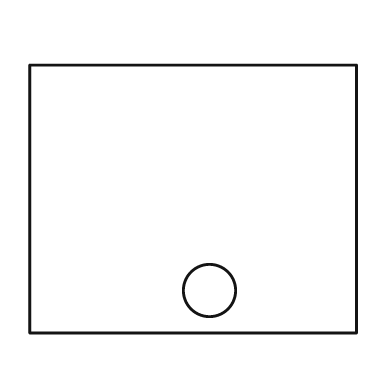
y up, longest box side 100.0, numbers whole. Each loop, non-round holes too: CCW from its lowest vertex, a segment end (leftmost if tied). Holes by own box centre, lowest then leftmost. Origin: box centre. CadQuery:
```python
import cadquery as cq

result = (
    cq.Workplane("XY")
    .moveTo(-50.0, -41.0)
    .lineTo(50.0, -41.0)
    .lineTo(50.0, 41.0)
    .lineTo(-50.0, 41.0)
    .close()
    .moveTo(5.0, -28.0)
    .circle(8.0)
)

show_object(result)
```